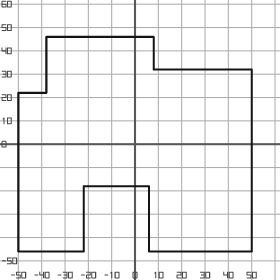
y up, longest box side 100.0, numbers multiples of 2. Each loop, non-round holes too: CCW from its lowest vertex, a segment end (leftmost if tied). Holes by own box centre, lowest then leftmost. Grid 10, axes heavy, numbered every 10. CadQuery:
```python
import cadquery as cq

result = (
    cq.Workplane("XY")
    .moveTo(-50.0, -46.0)
    .lineTo(-22.0, -46.0)
    .lineTo(-22.0, -18.0)
    .lineTo(6.0, -18.0)
    .lineTo(6.0, -46.0)
    .lineTo(50.0, -46.0)
    .lineTo(50.0, 32.0)
    .lineTo(8.0, 32.0)
    .lineTo(8.0, 46.0)
    .lineTo(-38.0, 46.0)
    .lineTo(-38.0, 22.0)
    .lineTo(-50.0, 22.0)
    .close()
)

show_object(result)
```